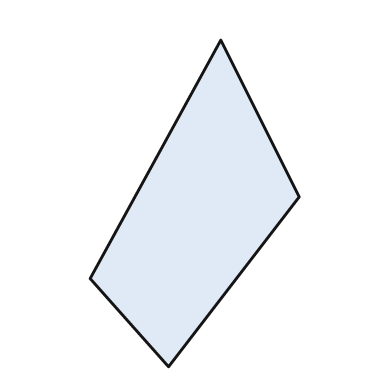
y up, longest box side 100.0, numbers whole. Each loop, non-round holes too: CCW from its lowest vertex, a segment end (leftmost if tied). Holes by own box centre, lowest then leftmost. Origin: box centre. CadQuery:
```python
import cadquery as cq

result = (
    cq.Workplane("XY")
    .moveTo(-8.0, -50.0)
    .lineTo(32.0, 2.0)
    .lineTo(8.0, 50.0)
    .lineTo(-32.0, -23.0)
    .close()
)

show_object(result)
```